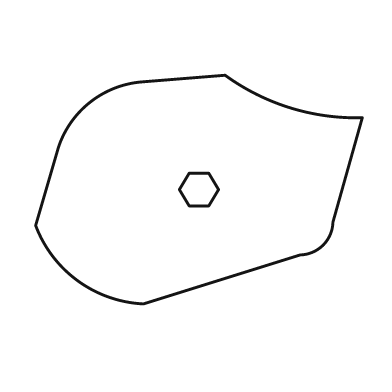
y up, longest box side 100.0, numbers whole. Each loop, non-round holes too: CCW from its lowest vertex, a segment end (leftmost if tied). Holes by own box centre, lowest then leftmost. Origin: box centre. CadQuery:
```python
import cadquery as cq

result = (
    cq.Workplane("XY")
    .moveTo(-17.0, -35.0)
    .lineTo(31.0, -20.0)
    .threePointArc((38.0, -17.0), (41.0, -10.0))
    .lineTo(50.0, 22.0)
    .threePointArc((28.0, 25.0), (8.0, 35.0))
    .lineTo(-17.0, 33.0)
    .threePointArc((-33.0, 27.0), (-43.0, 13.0))
    .lineTo(-50.0, -11.0)
    .threePointArc((-37.0, -28.0), (-17.0, -35.0))
    .close()
    .moveTo(-3.0, -5.0)
    .lineTo(3.0, -5.0)
    .lineTo(6.0, 0.0)
    .lineTo(3.0, 5.0)
    .lineTo(-3.0, 5.0)
    .lineTo(-6.0, 0.0)
    .close()
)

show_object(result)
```